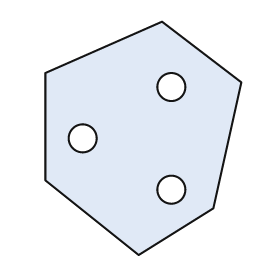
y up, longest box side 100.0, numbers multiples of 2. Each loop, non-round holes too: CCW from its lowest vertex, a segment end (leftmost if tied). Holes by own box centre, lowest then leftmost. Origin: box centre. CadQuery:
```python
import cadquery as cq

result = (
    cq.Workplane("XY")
    .moveTo(-2.0, -50.0)
    .lineTo(30.0, -30.0)
    .lineTo(42.0, 24.0)
    .lineTo(8.0, 50.0)
    .lineTo(-42.0, 28.0)
    .lineTo(-42.0, -18.0)
    .close()
    .moveTo(12.0, -22.0)
    .circle(6.0)
    .moveTo(-26.0, 0.0)
    .circle(6.0)
    .moveTo(12.0, 22.0)
    .circle(6.0)
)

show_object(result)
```